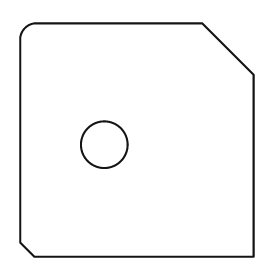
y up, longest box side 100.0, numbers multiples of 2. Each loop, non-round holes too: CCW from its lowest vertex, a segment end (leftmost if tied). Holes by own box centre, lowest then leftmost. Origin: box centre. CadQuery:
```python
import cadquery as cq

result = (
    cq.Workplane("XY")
    .moveTo(-44.0, -50.0)
    .lineTo(50.0, -50.0)
    .lineTo(50.0, 28.0)
    .lineTo(28.0, 50.0)
    .lineTo(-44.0, 50.0)
    .threePointArc((-48.0, 48.0), (-50.0, 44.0))
    .lineTo(-50.0, -44.0)
    .close()
    .moveTo(-14.0, -2.0)
    .circle(10.0)
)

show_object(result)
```